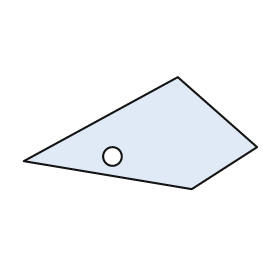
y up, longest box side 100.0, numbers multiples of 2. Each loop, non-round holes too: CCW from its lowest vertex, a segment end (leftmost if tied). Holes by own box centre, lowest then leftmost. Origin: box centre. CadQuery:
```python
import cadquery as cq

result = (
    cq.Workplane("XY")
    .moveTo(22.0, -24.0)
    .lineTo(50.0, -6.0)
    .lineTo(16.0, 24.0)
    .lineTo(-50.0, -12.0)
    .close()
    .moveTo(-12.0, -10.0)
    .circle(4.0)
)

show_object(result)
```